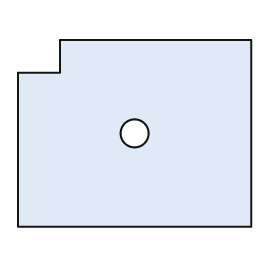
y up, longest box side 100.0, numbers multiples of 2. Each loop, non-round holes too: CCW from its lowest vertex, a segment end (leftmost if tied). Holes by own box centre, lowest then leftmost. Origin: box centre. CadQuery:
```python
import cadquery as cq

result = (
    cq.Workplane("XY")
    .moveTo(-50.0, -40.0)
    .lineTo(50.0, -40.0)
    .lineTo(50.0, 40.0)
    .lineTo(-32.0, 40.0)
    .lineTo(-32.0, 26.0)
    .lineTo(-50.0, 26.0)
    .close()
    .moveTo(0.0, 0.0)
    .circle(6.0)
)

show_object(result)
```